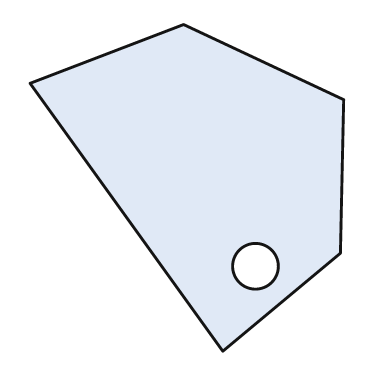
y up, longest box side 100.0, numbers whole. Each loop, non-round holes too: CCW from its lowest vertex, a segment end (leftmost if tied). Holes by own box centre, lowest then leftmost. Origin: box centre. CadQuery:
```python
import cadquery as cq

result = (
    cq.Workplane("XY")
    .moveTo(11.0, -50.0)
    .lineTo(47.0, -20.0)
    .lineTo(48.0, 27.0)
    .lineTo(-1.0, 50.0)
    .lineTo(-48.0, 32.0)
    .close()
    .moveTo(21.0, -24.0)
    .circle(7.0)
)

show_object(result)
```